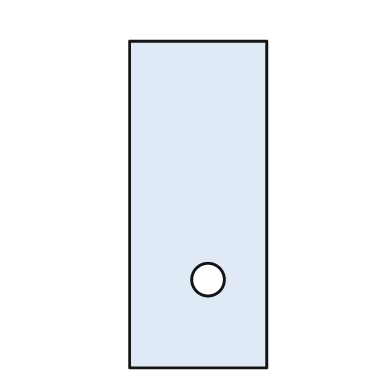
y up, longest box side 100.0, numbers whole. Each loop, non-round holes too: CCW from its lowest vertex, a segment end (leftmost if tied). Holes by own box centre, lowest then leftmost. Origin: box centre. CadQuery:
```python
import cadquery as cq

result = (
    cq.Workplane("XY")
    .moveTo(-21.0, -50.0)
    .lineTo(21.0, -50.0)
    .lineTo(21.0, 50.0)
    .lineTo(-21.0, 50.0)
    .close()
    .moveTo(3.0, -23.0)
    .circle(5.0)
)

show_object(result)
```